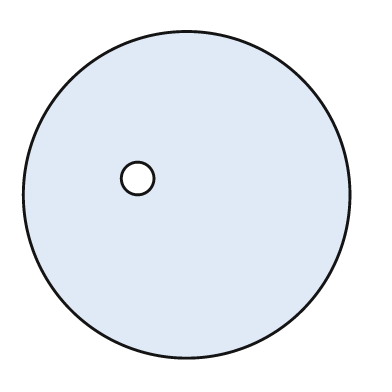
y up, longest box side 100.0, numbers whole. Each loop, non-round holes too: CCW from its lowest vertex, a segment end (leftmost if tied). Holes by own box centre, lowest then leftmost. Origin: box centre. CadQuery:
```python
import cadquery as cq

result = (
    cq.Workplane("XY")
    .moveTo(0.0, 0.0)
    .circle(50.0)
    .moveTo(-15.0, 5.0)
    .circle(5.0)
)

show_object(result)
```